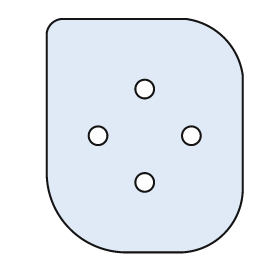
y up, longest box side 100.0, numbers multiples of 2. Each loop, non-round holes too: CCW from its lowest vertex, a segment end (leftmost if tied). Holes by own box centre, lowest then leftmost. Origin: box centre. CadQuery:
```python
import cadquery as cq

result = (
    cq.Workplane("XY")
    .moveTo(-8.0, -50.0)
    .lineTo(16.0, -50.0)
    .threePointArc((34.0, -42.0), (42.0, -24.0))
    .lineTo(42.0, 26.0)
    .threePointArc((34.0, 42.0), (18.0, 50.0))
    .lineTo(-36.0, 50.0)
    .threePointArc((-40.0, 48.0), (-42.0, 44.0))
    .lineTo(-42.0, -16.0)
    .threePointArc((-32.0, -40.0), (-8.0, -50.0))
    .close()
    .moveTo(0.0, -20.0)
    .circle(4.0)
    .moveTo(-20.0, 0.0)
    .circle(4.0)
    .moveTo(20.0, 0.0)
    .circle(4.0)
    .moveTo(0.0, 20.0)
    .circle(4.0)
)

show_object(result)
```